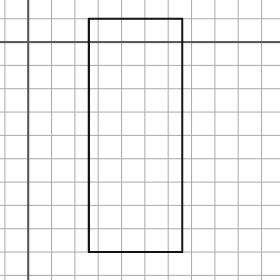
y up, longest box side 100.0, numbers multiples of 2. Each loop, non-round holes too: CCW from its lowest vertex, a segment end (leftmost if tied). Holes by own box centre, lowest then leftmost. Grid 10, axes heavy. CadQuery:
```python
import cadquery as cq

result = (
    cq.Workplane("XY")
    .moveTo(26.0, -90.0)
    .lineTo(66.0, -90.0)
    .lineTo(66.0, 10.0)
    .lineTo(26.0, 10.0)
    .close()
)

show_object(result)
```